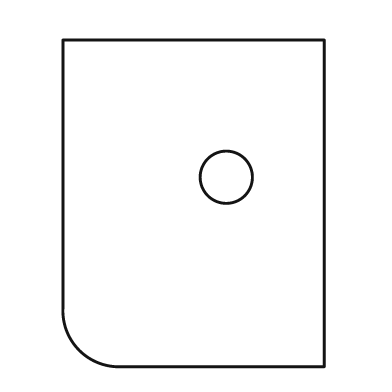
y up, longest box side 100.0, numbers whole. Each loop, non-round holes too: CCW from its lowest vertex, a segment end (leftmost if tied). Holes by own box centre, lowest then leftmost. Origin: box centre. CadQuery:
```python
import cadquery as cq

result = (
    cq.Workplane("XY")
    .moveTo(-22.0, -50.0)
    .lineTo(40.0, -50.0)
    .lineTo(40.0, 50.0)
    .lineTo(-40.0, 50.0)
    .lineTo(-40.0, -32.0)
    .threePointArc((-35.0, -45.0), (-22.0, -50.0))
    .close()
    .moveTo(10.0, 8.0)
    .circle(8.0)
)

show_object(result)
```